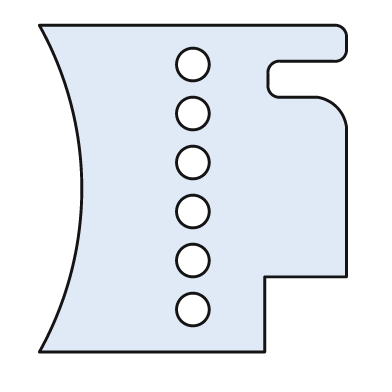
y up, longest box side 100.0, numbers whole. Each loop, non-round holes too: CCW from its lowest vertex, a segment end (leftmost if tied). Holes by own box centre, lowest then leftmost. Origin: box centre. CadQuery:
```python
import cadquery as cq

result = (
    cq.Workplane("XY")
    .moveTo(-47.0, -50.0)
    .lineTo(22.0, -50.0)
    .lineTo(22.0, -27.0)
    .lineTo(47.0, -27.0)
    .lineTo(47.0, 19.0)
    .threePointArc((44.0, 25.0), (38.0, 28.0))
    .lineTo(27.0, 28.0)
    .threePointArc((24.0, 29.0), (23.0, 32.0))
    .lineTo(23.0, 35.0)
    .threePointArc((24.0, 38.0), (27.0, 39.0))
    .lineTo(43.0, 39.0)
    .threePointArc((46.0, 40.0), (47.0, 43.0))
    .lineTo(47.0, 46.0)
    .threePointArc((46.0, 49.0), (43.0, 50.0))
    .lineTo(-47.0, 50.0)
    .threePointArc((-34.0, 0.0), (-47.0, -50.0))
    .close()
    .moveTo(0.0, -37.0)
    .circle(5.0)
    .moveTo(0.0, -22.0)
    .circle(5.0)
    .moveTo(0.0, -7.0)
    .circle(5.0)
    .moveTo(0.0, 8.0)
    .circle(5.0)
    .moveTo(0.0, 23.0)
    .circle(5.0)
    .moveTo(0.0, 38.0)
    .circle(5.0)
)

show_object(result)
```